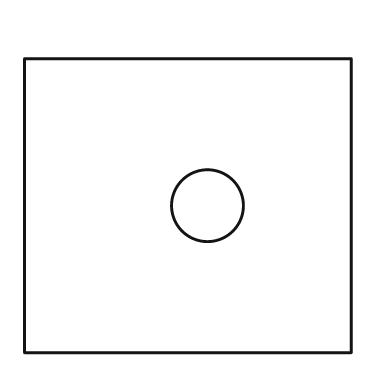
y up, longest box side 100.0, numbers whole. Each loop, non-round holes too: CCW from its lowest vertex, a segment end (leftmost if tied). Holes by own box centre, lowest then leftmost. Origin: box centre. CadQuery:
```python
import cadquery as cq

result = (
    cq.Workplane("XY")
    .moveTo(-50.0, -45.0)
    .lineTo(50.0, -45.0)
    .lineTo(50.0, 45.0)
    .lineTo(-50.0, 45.0)
    .close()
    .moveTo(6.0, 0.0)
    .circle(11.0)
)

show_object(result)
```